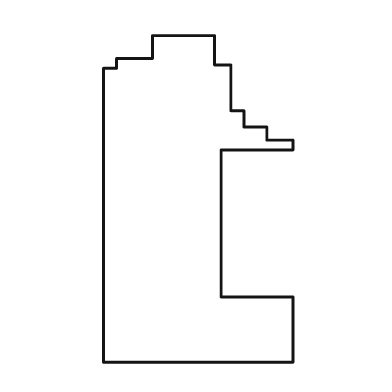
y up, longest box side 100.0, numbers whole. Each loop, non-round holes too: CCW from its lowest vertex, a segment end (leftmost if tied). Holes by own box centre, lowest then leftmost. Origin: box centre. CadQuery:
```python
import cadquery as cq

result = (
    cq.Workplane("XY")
    .moveTo(-29.0, -50.0)
    .lineTo(29.0, -50.0)
    .lineTo(29.0, -30.0)
    .lineTo(7.0, -30.0)
    .lineTo(7.0, 15.0)
    .lineTo(29.0, 15.0)
    .lineTo(29.0, 18.0)
    .lineTo(21.0, 18.0)
    .lineTo(21.0, 22.0)
    .lineTo(14.0, 22.0)
    .lineTo(14.0, 27.0)
    .lineTo(10.0, 27.0)
    .lineTo(10.0, 41.0)
    .lineTo(5.0, 41.0)
    .lineTo(5.0, 50.0)
    .lineTo(-14.0, 50.0)
    .lineTo(-14.0, 43.0)
    .lineTo(-25.0, 43.0)
    .lineTo(-25.0, 40.0)
    .lineTo(-29.0, 40.0)
    .close()
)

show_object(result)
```